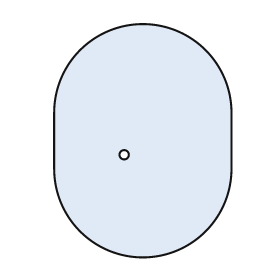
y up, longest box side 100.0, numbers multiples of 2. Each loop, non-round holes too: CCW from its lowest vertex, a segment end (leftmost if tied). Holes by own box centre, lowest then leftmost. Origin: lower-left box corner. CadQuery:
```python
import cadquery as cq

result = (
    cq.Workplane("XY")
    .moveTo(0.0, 38.0)
    .threePointArc((38.0, 0.0), (76.0, 38.0))
    .lineTo(76.0, 62.0)
    .threePointArc((38.0, 100.0), (0.0, 62.0))
    .close()
    .moveTo(30.0, 44.0)
    .circle(2.0)
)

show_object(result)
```